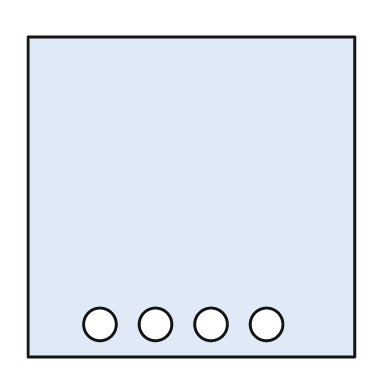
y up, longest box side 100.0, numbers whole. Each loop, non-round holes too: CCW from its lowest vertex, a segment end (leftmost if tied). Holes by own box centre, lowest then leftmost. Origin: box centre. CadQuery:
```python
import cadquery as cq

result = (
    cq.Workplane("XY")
    .moveTo(-50.0, -49.0)
    .lineTo(50.0, -49.0)
    .lineTo(50.0, 49.0)
    .lineTo(-50.0, 49.0)
    .close()
    .moveTo(-28.0, -39.0)
    .circle(5.0)
    .moveTo(-11.0, -39.0)
    .circle(5.0)
    .moveTo(6.0, -39.0)
    .circle(5.0)
    .moveTo(23.0, -39.0)
    .circle(5.0)
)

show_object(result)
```